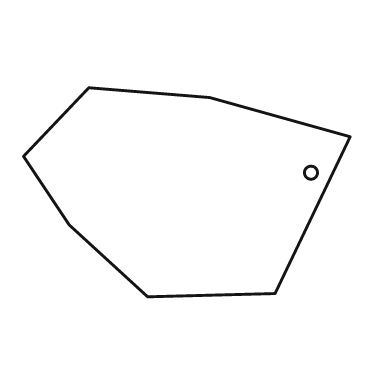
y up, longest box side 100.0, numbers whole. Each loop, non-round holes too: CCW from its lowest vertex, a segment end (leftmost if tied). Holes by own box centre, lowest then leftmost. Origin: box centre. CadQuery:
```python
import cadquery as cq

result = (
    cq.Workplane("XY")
    .moveTo(-12.0, -32.0)
    .lineTo(27.0, -31.0)
    .lineTo(50.0, 17.0)
    .lineTo(7.0, 29.0)
    .lineTo(-30.0, 32.0)
    .lineTo(-50.0, 11.0)
    .lineTo(-36.0, -10.0)
    .close()
    .moveTo(38.0, 6.0)
    .circle(2.0)
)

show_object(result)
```